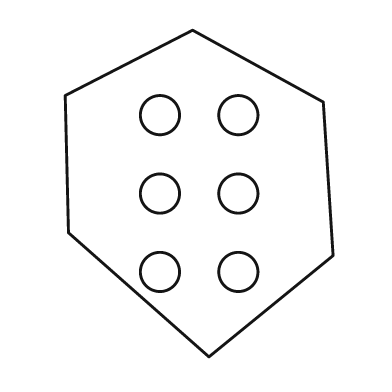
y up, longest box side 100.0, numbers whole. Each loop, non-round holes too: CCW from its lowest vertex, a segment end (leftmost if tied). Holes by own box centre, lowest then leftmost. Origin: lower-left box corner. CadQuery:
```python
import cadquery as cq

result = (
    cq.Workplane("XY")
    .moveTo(44.0, 0.0)
    .lineTo(82.0, 31.0)
    .lineTo(79.0, 78.0)
    .lineTo(39.0, 100.0)
    .lineTo(0.0, 80.0)
    .lineTo(1.0, 38.0)
    .close()
    .moveTo(29.0, 26.0)
    .circle(6.0)
    .moveTo(53.0, 26.0)
    .circle(6.0)
    .moveTo(29.0, 50.0)
    .circle(6.0)
    .moveTo(53.0, 50.0)
    .circle(6.0)
    .moveTo(29.0, 74.0)
    .circle(6.0)
    .moveTo(53.0, 74.0)
    .circle(6.0)
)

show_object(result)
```